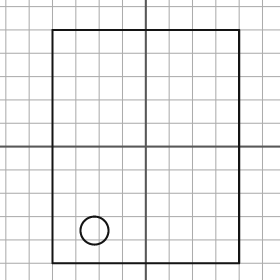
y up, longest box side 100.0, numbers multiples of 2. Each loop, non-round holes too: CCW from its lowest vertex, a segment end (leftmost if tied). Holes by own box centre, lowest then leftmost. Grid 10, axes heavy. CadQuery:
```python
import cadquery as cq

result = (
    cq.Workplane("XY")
    .moveTo(-40.0, -50.0)
    .lineTo(40.0, -50.0)
    .lineTo(40.0, 50.0)
    .lineTo(-40.0, 50.0)
    .close()
    .moveTo(-22.0, -36.0)
    .circle(6.0)
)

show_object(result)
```